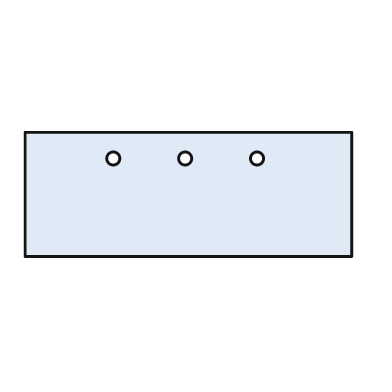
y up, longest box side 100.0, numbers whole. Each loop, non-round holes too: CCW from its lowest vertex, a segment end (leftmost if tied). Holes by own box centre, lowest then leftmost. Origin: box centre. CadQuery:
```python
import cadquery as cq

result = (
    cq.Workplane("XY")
    .moveTo(-50.0, -19.0)
    .lineTo(50.0, -19.0)
    .lineTo(50.0, 19.0)
    .lineTo(-50.0, 19.0)
    .close()
    .moveTo(-23.0, 11.0)
    .circle(2.0)
    .moveTo(-1.0, 11.0)
    .circle(2.0)
    .moveTo(21.0, 11.0)
    .circle(2.0)
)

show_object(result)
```